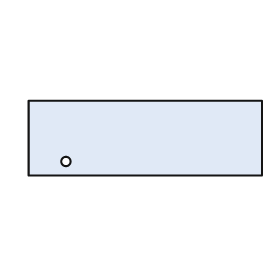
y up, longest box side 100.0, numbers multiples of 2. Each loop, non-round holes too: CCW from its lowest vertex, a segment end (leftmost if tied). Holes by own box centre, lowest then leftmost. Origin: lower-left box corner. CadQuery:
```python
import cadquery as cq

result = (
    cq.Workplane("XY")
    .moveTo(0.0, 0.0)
    .lineTo(100.0, 0.0)
    .lineTo(100.0, 32.0)
    .lineTo(0.0, 32.0)
    .close()
    .moveTo(16.0, 6.0)
    .circle(2.0)
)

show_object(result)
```